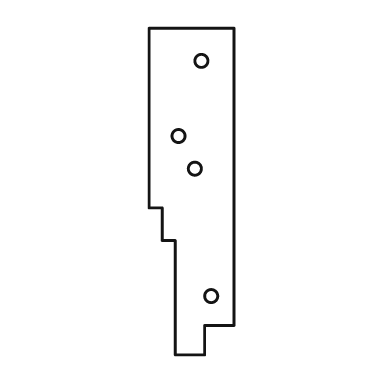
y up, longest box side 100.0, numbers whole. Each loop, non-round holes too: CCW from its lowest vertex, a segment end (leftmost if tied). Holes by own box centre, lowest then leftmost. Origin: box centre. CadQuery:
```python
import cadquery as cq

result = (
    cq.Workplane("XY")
    .moveTo(-5.0, -50.0)
    .lineTo(4.0, -50.0)
    .lineTo(4.0, -41.0)
    .lineTo(13.0, -41.0)
    .lineTo(13.0, 50.0)
    .lineTo(-13.0, 50.0)
    .lineTo(-13.0, -5.0)
    .lineTo(-9.0, -5.0)
    .lineTo(-9.0, -15.0)
    .lineTo(-5.0, -15.0)
    .close()
    .moveTo(6.0, -32.0)
    .circle(2.0)
    .moveTo(1.0, 7.0)
    .circle(2.0)
    .moveTo(-4.0, 17.0)
    .circle(2.0)
    .moveTo(3.0, 40.0)
    .circle(2.0)
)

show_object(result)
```